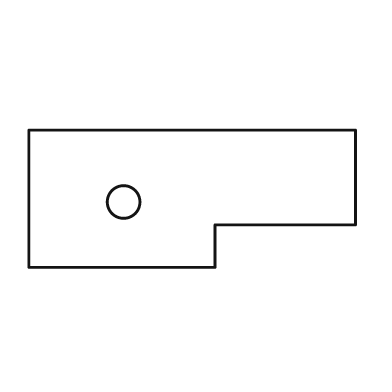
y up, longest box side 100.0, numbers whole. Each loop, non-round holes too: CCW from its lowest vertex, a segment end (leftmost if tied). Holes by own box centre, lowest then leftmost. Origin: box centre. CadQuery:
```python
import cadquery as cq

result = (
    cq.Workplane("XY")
    .moveTo(-50.0, -21.0)
    .lineTo(7.0, -21.0)
    .lineTo(7.0, -8.0)
    .lineTo(50.0, -8.0)
    .lineTo(50.0, 21.0)
    .lineTo(-50.0, 21.0)
    .close()
    .moveTo(-21.0, -1.0)
    .circle(5.0)
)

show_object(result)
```